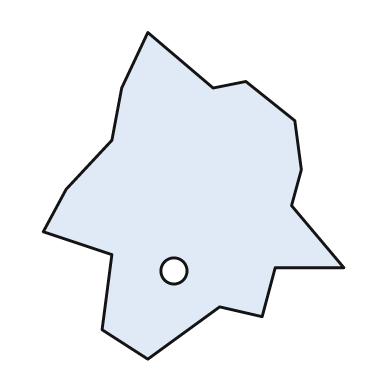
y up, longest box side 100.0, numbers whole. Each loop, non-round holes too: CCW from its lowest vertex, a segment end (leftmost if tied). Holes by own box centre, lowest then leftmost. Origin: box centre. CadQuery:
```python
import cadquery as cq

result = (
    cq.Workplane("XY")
    .moveTo(-14.0, -50.0)
    .lineTo(8.0, -34.0)
    .lineTo(21.0, -37.0)
    .lineTo(25.0, -22.0)
    .lineTo(46.0, -22.0)
    .lineTo(30.0, -3.0)
    .lineTo(33.0, 8.0)
    .lineTo(31.0, 23.0)
    .lineTo(16.0, 35.0)
    .lineTo(6.0, 33.0)
    .lineTo(-14.0, 50.0)
    .lineTo(-22.0, 33.0)
    .lineTo(-25.0, 17.0)
    .lineTo(-39.0, 2.0)
    .lineTo(-46.0, -11.0)
    .lineTo(-25.0, -18.0)
    .lineTo(-28.0, -41.0)
    .close()
    .moveTo(-6.0, -23.0)
    .circle(4.0)
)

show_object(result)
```